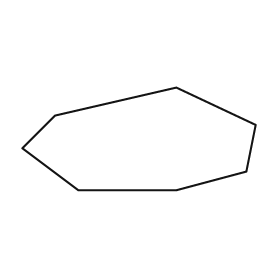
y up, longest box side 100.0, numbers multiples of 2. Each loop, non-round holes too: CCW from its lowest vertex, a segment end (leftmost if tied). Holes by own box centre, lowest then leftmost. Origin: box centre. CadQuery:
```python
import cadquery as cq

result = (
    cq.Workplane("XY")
    .moveTo(-26.0, -22.0)
    .lineTo(16.0, -22.0)
    .lineTo(46.0, -14.0)
    .lineTo(50.0, 6.0)
    .lineTo(16.0, 22.0)
    .lineTo(-36.0, 10.0)
    .lineTo(-50.0, -4.0)
    .close()
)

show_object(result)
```